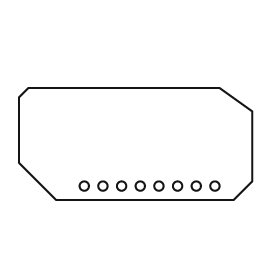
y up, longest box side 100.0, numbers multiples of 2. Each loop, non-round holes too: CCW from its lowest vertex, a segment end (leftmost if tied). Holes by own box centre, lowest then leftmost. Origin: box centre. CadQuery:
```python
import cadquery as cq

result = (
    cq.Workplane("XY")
    .moveTo(-34.0, -24.0)
    .lineTo(42.0, -24.0)
    .lineTo(50.0, -16.0)
    .lineTo(50.0, 14.0)
    .lineTo(36.0, 24.0)
    .lineTo(-46.0, 24.0)
    .lineTo(-50.0, 20.0)
    .lineTo(-50.0, -8.0)
    .close()
    .moveTo(-22.0, -18.0)
    .circle(2.0)
    .moveTo(-14.0, -18.0)
    .circle(2.0)
    .moveTo(-6.0, -18.0)
    .circle(2.0)
    .moveTo(2.0, -18.0)
    .circle(2.0)
    .moveTo(10.0, -18.0)
    .circle(2.0)
    .moveTo(18.0, -18.0)
    .circle(2.0)
    .moveTo(26.0, -18.0)
    .circle(2.0)
    .moveTo(34.0, -18.0)
    .circle(2.0)
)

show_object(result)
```